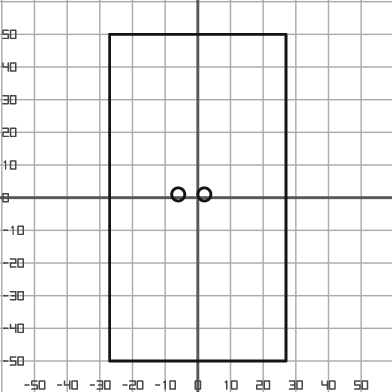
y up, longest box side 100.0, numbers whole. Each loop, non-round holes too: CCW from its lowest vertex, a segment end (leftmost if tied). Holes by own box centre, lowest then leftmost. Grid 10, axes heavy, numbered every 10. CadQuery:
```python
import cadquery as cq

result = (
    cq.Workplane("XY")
    .moveTo(-27.0, -50.0)
    .lineTo(27.0, -50.0)
    .lineTo(27.0, 50.0)
    .lineTo(-27.0, 50.0)
    .close()
    .moveTo(-6.0, 1.0)
    .circle(2.0)
    .moveTo(2.0, 1.0)
    .circle(2.0)
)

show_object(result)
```